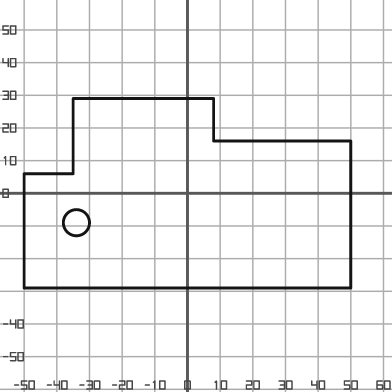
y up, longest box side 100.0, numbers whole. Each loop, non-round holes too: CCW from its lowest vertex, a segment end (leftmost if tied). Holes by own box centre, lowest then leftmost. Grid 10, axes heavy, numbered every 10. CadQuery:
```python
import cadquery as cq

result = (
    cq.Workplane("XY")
    .moveTo(-50.0, -29.0)
    .lineTo(50.0, -29.0)
    .lineTo(50.0, 16.0)
    .lineTo(8.0, 16.0)
    .lineTo(8.0, 29.0)
    .lineTo(-35.0, 29.0)
    .lineTo(-35.0, 6.0)
    .lineTo(-50.0, 6.0)
    .close()
    .moveTo(-34.0, -9.0)
    .circle(4.0)
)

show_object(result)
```